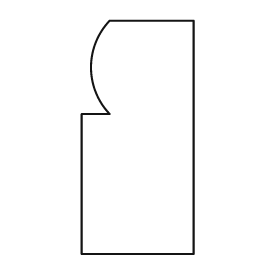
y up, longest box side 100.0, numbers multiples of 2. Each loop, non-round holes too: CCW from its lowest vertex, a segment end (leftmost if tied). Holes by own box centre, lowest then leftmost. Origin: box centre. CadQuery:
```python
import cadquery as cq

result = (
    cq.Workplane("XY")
    .moveTo(-24.0, -50.0)
    .lineTo(24.0, -50.0)
    .lineTo(24.0, 50.0)
    .lineTo(-12.0, 50.0)
    .threePointArc((-20.0, 30.0), (-12.0, 10.0))
    .lineTo(-24.0, 10.0)
    .close()
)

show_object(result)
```